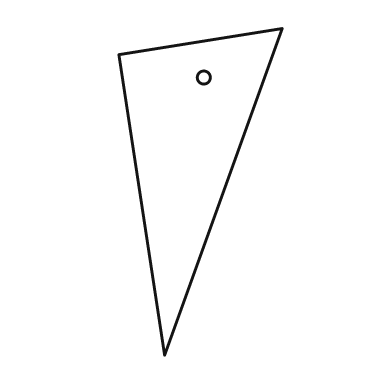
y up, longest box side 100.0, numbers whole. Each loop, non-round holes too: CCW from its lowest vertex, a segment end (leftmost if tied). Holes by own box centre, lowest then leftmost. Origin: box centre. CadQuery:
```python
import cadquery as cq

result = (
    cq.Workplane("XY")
    .moveTo(-11.0, -50.0)
    .lineTo(25.0, 50.0)
    .lineTo(-25.0, 42.0)
    .close()
    .moveTo(1.0, 35.0)
    .circle(2.0)
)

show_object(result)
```